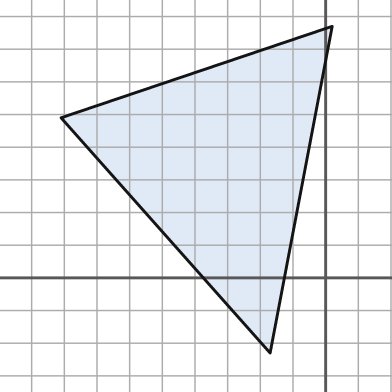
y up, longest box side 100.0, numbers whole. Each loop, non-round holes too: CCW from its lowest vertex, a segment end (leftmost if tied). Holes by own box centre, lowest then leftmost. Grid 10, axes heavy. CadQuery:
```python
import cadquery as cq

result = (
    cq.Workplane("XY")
    .moveTo(-17.0, -23.0)
    .lineTo(2.0, 77.0)
    .lineTo(-81.0, 49.0)
    .close()
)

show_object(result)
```